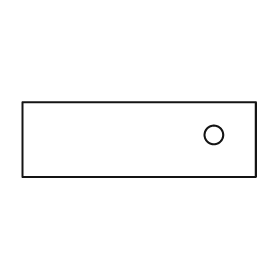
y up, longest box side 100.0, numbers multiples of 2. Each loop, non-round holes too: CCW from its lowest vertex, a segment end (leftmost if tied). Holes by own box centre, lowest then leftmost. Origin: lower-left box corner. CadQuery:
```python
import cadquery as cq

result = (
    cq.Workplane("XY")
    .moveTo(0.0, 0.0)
    .lineTo(100.0, 0.0)
    .lineTo(100.0, 32.0)
    .lineTo(0.0, 32.0)
    .close()
    .moveTo(82.0, 18.0)
    .circle(4.0)
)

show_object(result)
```